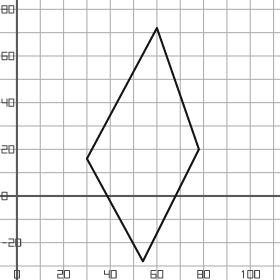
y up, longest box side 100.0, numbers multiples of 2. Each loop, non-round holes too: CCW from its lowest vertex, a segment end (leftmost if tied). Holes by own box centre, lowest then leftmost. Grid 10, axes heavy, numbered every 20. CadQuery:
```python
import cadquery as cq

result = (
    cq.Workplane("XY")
    .moveTo(54.0, -28.0)
    .lineTo(78.0, 20.0)
    .lineTo(60.0, 72.0)
    .lineTo(30.0, 16.0)
    .close()
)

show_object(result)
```